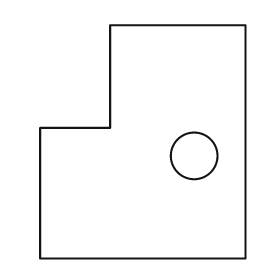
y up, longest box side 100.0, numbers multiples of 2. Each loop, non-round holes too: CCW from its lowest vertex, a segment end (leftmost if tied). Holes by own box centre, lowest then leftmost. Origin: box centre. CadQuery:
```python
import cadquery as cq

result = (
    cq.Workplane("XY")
    .moveTo(-44.0, -50.0)
    .lineTo(44.0, -50.0)
    .lineTo(44.0, 50.0)
    .lineTo(-14.0, 50.0)
    .lineTo(-14.0, 6.0)
    .lineTo(-44.0, 6.0)
    .close()
    .moveTo(22.0, -6.0)
    .circle(10.0)
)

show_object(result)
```